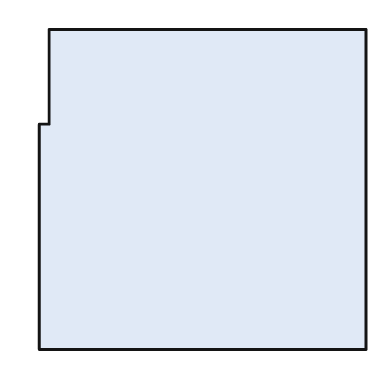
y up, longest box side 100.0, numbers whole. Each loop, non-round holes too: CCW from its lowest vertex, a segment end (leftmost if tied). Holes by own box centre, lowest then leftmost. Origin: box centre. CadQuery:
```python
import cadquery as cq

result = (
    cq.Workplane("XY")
    .moveTo(-50.0, -49.0)
    .lineTo(50.0, -49.0)
    .lineTo(50.0, 49.0)
    .lineTo(-47.0, 49.0)
    .lineTo(-47.0, 20.0)
    .lineTo(-50.0, 20.0)
    .close()
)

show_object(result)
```